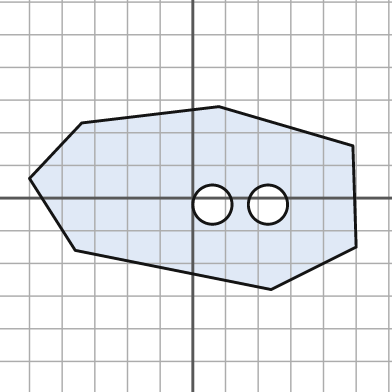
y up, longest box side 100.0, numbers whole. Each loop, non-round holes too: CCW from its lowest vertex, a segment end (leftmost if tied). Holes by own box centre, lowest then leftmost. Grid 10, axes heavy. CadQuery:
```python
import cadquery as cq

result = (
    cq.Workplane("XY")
    .moveTo(24.0, -28.0)
    .lineTo(50.0, -15.0)
    .lineTo(49.0, 16.0)
    .lineTo(8.0, 28.0)
    .lineTo(-34.0, 23.0)
    .lineTo(-50.0, 6.0)
    .lineTo(-36.0, -16.0)
    .close()
    .moveTo(6.0, -2.0)
    .circle(6.0)
    .moveTo(23.0, -2.0)
    .circle(6.0)
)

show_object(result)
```